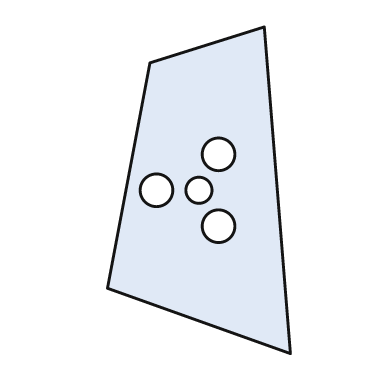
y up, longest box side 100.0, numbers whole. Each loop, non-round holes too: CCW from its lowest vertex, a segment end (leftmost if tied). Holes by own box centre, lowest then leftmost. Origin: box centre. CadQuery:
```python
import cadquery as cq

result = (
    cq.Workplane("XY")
    .moveTo(28.0, -50.0)
    .lineTo(20.0, 50.0)
    .lineTo(-15.0, 39.0)
    .lineTo(-28.0, -30.0)
    .close()
    .moveTo(6.0, -11.0)
    .circle(5.0)
    .moveTo(-13.0, 0.0)
    .circle(5.0)
    .moveTo(0.0, 0.0)
    .circle(4.0)
    .moveTo(6.0, 11.0)
    .circle(5.0)
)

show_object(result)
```